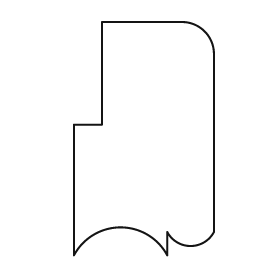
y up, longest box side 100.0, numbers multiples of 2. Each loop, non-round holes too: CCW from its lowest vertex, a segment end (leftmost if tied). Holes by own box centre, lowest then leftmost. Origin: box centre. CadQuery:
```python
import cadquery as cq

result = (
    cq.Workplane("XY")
    .moveTo(-30.0, -50.0)
    .threePointArc((-10.0, -38.0), (10.0, -50.0))
    .lineTo(10.0, -40.0)
    .threePointArc((20.0, -46.0), (30.0, -40.0))
    .lineTo(30.0, 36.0)
    .threePointArc((26.0, 46.0), (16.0, 50.0))
    .lineTo(-18.0, 50.0)
    .lineTo(-18.0, 6.0)
    .lineTo(-30.0, 6.0)
    .close()
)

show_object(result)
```